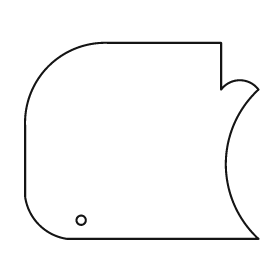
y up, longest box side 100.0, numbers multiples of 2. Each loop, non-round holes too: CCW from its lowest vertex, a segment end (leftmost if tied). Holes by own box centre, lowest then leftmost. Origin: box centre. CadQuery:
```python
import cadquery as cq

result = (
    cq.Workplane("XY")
    .moveTo(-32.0, -42.0)
    .lineTo(50.0, -42.0)
    .threePointArc((36.0, -10.0), (50.0, 22.0))
    .threePointArc((42.0, 26.0), (34.0, 22.0))
    .lineTo(34.0, 42.0)
    .lineTo(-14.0, 42.0)
    .threePointArc((-40.0, 32.0), (-50.0, 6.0))
    .lineTo(-50.0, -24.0)
    .threePointArc((-44.0, -36.0), (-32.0, -42.0))
    .close()
    .moveTo(-26.0, -34.0)
    .circle(2.0)
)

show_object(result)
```